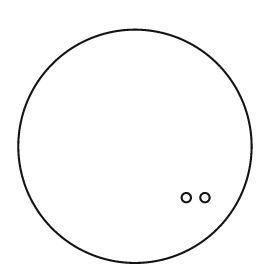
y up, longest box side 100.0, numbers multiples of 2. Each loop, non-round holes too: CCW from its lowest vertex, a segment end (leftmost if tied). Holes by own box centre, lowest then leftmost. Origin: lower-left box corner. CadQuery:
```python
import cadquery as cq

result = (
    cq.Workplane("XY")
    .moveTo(50.0, 50.0)
    .circle(50.0)
    .moveTo(72.0, 28.0)
    .circle(2.0)
    .moveTo(80.0, 28.0)
    .circle(2.0)
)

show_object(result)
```